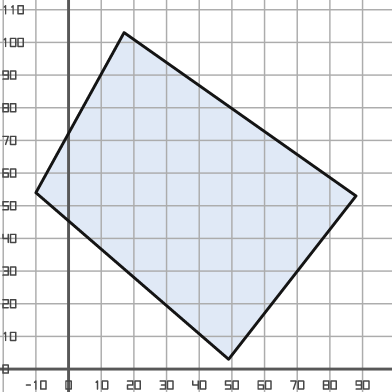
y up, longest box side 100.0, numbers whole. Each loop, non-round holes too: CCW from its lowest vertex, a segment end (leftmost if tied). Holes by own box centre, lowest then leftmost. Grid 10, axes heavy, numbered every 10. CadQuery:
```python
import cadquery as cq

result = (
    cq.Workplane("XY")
    .moveTo(49.0, 3.0)
    .lineTo(88.0, 53.0)
    .lineTo(17.0, 103.0)
    .lineTo(-10.0, 54.0)
    .close()
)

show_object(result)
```